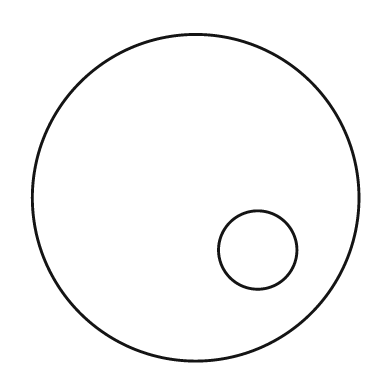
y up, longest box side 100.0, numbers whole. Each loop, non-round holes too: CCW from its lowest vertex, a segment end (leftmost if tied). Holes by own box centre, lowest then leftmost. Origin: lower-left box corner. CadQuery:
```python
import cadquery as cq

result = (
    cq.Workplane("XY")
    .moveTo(50.0, 50.0)
    .circle(50.0)
    .moveTo(69.0, 34.0)
    .circle(12.0)
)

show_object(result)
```